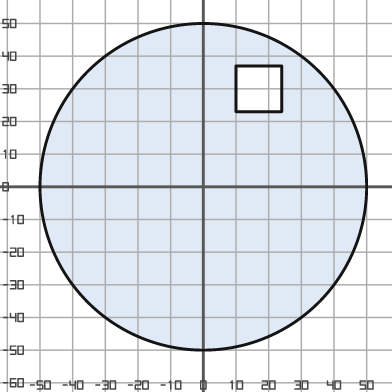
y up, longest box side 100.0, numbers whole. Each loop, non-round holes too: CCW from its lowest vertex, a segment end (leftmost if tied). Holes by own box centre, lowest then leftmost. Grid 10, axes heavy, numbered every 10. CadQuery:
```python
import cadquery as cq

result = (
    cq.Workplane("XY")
    .moveTo(0.0, 0.0)
    .circle(50.0)
    .moveTo(10.0, 23.0)
    .lineTo(24.0, 23.0)
    .lineTo(24.0, 37.0)
    .lineTo(10.0, 37.0)
    .close()
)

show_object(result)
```